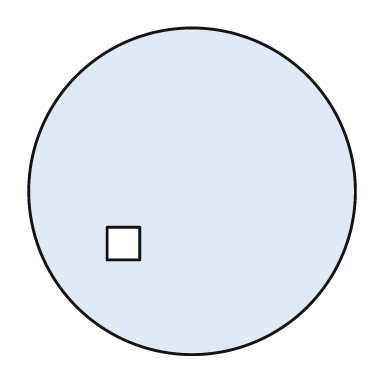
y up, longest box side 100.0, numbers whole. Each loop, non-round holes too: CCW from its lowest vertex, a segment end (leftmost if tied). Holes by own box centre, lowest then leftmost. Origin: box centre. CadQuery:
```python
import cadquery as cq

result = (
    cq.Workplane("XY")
    .moveTo(0.0, 0.0)
    .circle(50.0)
    .moveTo(-26.0, -21.0)
    .lineTo(-16.0, -21.0)
    .lineTo(-16.0, -11.0)
    .lineTo(-26.0, -11.0)
    .close()
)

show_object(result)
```